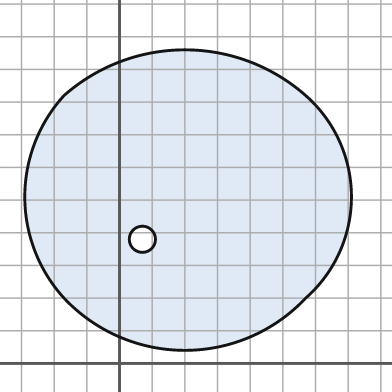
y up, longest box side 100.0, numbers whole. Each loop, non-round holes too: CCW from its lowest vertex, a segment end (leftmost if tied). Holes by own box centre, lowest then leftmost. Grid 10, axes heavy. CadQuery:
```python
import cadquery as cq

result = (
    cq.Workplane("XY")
    .moveTo(-17.0, 20.0)
    .threePointArc((20.0, 4.0), (57.0, 20.0))
    .threePointArc((71.0, 51.0), (57.0, 82.0))
    .threePointArc((20.0, 96.0), (-17.0, 82.0))
    .threePointArc((-29.0, 51.0), (-17.0, 20.0))
    .close()
    .moveTo(7.0, 38.0)
    .circle(4.0)
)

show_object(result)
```